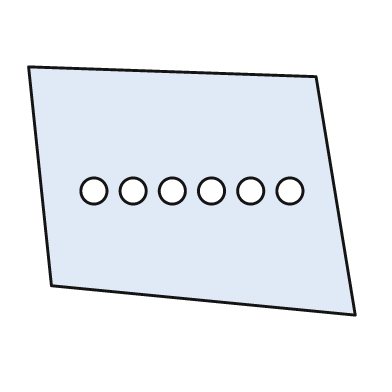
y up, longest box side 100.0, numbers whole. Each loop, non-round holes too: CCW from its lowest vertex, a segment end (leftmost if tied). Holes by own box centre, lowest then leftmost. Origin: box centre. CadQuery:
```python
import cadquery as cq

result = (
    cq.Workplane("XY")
    .moveTo(50.0, -38.0)
    .lineTo(38.0, 35.0)
    .lineTo(-50.0, 38.0)
    .lineTo(-43.0, -29.0)
    .close()
    .moveTo(-30.0, 0.0)
    .circle(4.0)
    .moveTo(-18.0, 0.0)
    .circle(4.0)
    .moveTo(-6.0, 0.0)
    .circle(4.0)
    .moveTo(6.0, 0.0)
    .circle(4.0)
    .moveTo(18.0, 0.0)
    .circle(4.0)
    .moveTo(30.0, 0.0)
    .circle(4.0)
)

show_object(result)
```